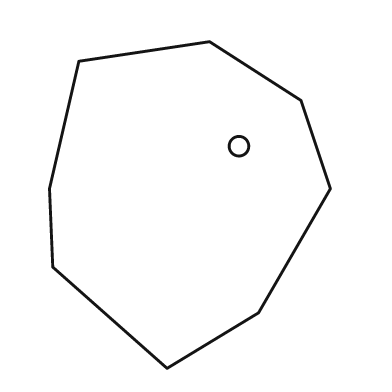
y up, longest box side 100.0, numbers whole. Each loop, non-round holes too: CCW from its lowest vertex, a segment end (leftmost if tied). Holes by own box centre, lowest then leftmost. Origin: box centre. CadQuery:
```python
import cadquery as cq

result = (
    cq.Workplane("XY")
    .moveTo(-7.0, -50.0)
    .lineTo(21.0, -33.0)
    .lineTo(43.0, 5.0)
    .lineTo(34.0, 32.0)
    .lineTo(6.0, 50.0)
    .lineTo(-34.0, 44.0)
    .lineTo(-43.0, 5.0)
    .lineTo(-42.0, -19.0)
    .close()
    .moveTo(15.0, 18.0)
    .circle(3.0)
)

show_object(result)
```